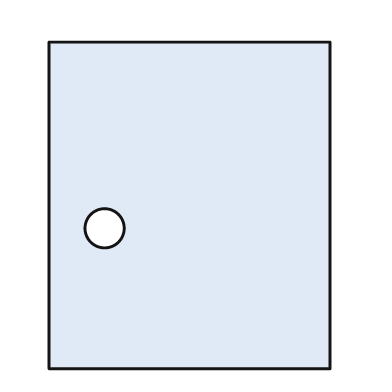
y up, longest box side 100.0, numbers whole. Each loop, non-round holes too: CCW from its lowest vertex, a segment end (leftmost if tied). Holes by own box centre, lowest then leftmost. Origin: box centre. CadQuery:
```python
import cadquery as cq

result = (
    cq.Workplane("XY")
    .moveTo(-43.0, -50.0)
    .lineTo(43.0, -50.0)
    .lineTo(43.0, 50.0)
    .lineTo(-43.0, 50.0)
    .close()
    .moveTo(-26.0, -7.0)
    .circle(6.0)
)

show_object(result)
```